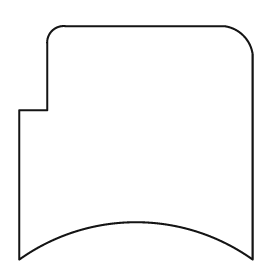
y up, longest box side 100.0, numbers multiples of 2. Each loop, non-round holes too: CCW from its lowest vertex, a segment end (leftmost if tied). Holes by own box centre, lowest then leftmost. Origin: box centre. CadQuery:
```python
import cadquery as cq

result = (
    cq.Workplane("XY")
    .moveTo(-50.0, -50.0)
    .threePointArc((0.0, -34.0), (50.0, -50.0))
    .lineTo(50.0, 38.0)
    .threePointArc((46.0, 46.0), (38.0, 50.0))
    .lineTo(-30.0, 50.0)
    .threePointArc((-36.0, 48.0), (-38.0, 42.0))
    .lineTo(-38.0, 14.0)
    .lineTo(-50.0, 14.0)
    .close()
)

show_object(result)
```